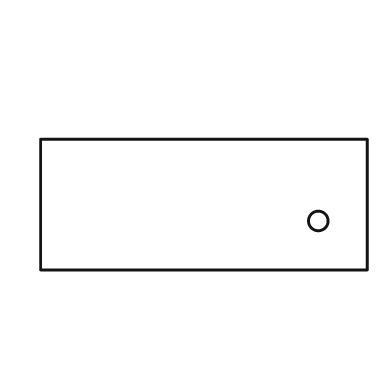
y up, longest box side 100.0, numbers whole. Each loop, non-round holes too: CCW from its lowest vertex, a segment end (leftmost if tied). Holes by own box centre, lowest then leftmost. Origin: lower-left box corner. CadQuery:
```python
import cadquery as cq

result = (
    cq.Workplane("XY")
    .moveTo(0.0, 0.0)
    .lineTo(100.0, 0.0)
    .lineTo(100.0, 40.0)
    .lineTo(0.0, 40.0)
    .close()
    .moveTo(85.0, 15.0)
    .circle(3.0)
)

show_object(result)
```